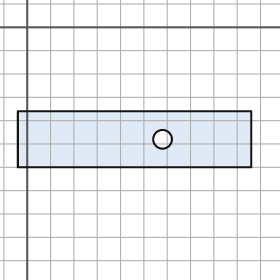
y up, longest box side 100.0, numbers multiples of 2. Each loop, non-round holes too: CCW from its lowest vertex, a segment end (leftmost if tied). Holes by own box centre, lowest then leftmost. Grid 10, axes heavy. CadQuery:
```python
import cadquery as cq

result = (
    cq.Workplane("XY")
    .moveTo(-4.0, -60.0)
    .lineTo(96.0, -60.0)
    .lineTo(96.0, -36.0)
    .lineTo(-4.0, -36.0)
    .close()
    .moveTo(58.0, -48.0)
    .circle(4.0)
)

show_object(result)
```